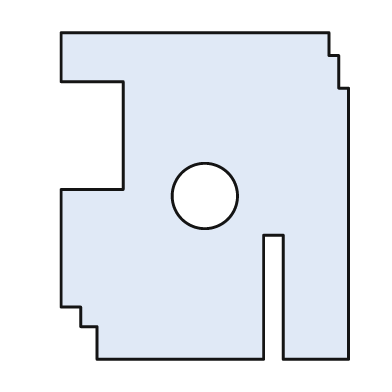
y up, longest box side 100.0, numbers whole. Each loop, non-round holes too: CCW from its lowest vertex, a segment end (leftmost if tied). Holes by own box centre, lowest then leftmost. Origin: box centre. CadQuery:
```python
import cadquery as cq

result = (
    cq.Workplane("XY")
    .moveTo(-33.0, -50.0)
    .lineTo(18.0, -50.0)
    .lineTo(18.0, -12.0)
    .lineTo(24.0, -12.0)
    .lineTo(24.0, -50.0)
    .lineTo(44.0, -50.0)
    .lineTo(44.0, 33.0)
    .lineTo(41.0, 33.0)
    .lineTo(41.0, 43.0)
    .lineTo(38.0, 43.0)
    .lineTo(38.0, 50.0)
    .lineTo(-44.0, 50.0)
    .lineTo(-44.0, 35.0)
    .lineTo(-25.0, 35.0)
    .lineTo(-25.0, 2.0)
    .lineTo(-44.0, 2.0)
    .lineTo(-44.0, -34.0)
    .lineTo(-38.0, -34.0)
    .lineTo(-38.0, -40.0)
    .lineTo(-33.0, -40.0)
    .close()
    .moveTo(0.0, 0.0)
    .circle(10.0)
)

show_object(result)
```